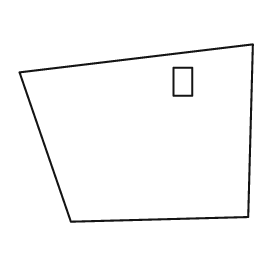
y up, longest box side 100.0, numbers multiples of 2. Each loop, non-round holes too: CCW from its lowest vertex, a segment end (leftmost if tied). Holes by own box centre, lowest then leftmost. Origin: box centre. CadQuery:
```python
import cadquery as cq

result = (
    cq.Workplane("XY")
    .moveTo(-28.0, -38.0)
    .lineTo(48.0, -36.0)
    .lineTo(50.0, 38.0)
    .lineTo(-50.0, 26.0)
    .close()
    .moveTo(16.0, 16.0)
    .lineTo(24.0, 16.0)
    .lineTo(24.0, 28.0)
    .lineTo(16.0, 28.0)
    .close()
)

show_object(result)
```